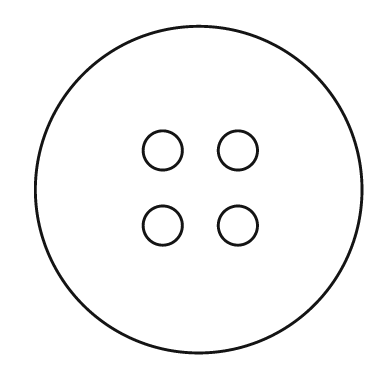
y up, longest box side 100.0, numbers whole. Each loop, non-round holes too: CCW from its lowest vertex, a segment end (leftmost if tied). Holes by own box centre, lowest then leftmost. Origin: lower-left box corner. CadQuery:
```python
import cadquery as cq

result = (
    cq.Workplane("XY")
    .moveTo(50.0, 50.0)
    .circle(50.0)
    .moveTo(39.0, 39.0)
    .circle(6.0)
    .moveTo(62.0, 39.0)
    .circle(6.0)
    .moveTo(39.0, 62.0)
    .circle(6.0)
    .moveTo(62.0, 62.0)
    .circle(6.0)
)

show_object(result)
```